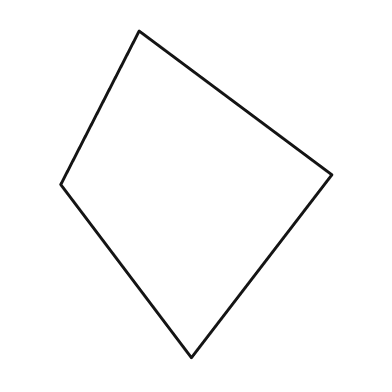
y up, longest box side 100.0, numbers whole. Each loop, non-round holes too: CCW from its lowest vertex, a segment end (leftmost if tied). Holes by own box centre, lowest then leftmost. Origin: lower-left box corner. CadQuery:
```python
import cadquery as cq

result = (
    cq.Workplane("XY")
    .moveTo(40.0, 0.0)
    .lineTo(83.0, 56.0)
    .lineTo(24.0, 100.0)
    .lineTo(0.0, 53.0)
    .close()
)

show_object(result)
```